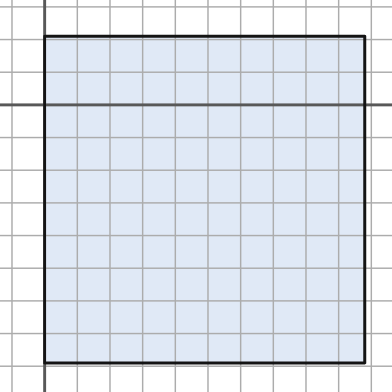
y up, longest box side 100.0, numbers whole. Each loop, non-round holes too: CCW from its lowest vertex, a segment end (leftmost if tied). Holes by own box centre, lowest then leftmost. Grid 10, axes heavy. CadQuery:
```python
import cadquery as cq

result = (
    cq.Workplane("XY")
    .moveTo(0.0, -79.0)
    .lineTo(98.0, -79.0)
    .lineTo(98.0, 21.0)
    .lineTo(0.0, 21.0)
    .close()
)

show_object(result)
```